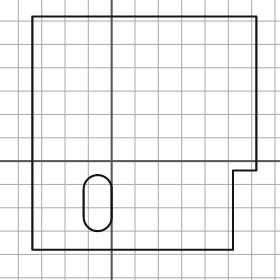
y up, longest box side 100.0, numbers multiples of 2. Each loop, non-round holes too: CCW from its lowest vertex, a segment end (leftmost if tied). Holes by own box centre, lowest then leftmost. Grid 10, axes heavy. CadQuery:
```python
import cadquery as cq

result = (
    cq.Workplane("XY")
    .moveTo(-34.0, -38.0)
    .lineTo(52.0, -38.0)
    .lineTo(52.0, -4.0)
    .lineTo(62.0, -4.0)
    .lineTo(62.0, 62.0)
    .lineTo(-34.0, 62.0)
    .close()
    .moveTo(-12.0, -24.0)
    .threePointArc((-6.0, -30.0), (0.0, -24.0))
    .lineTo(0.0, -12.0)
    .threePointArc((-6.0, -6.0), (-12.0, -12.0))
    .close()
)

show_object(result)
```